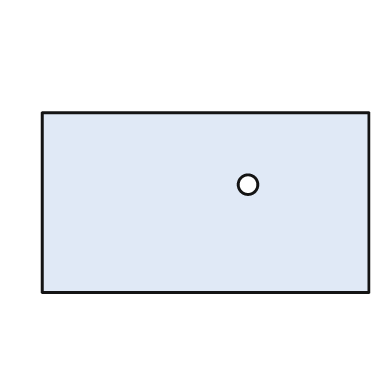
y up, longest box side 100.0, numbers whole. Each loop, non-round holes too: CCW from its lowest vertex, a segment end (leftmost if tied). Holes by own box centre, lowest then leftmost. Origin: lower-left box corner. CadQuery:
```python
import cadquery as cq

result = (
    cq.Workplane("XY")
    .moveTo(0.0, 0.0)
    .lineTo(100.0, 0.0)
    .lineTo(100.0, 55.0)
    .lineTo(0.0, 55.0)
    .close()
    .moveTo(63.0, 33.0)
    .circle(3.0)
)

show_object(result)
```